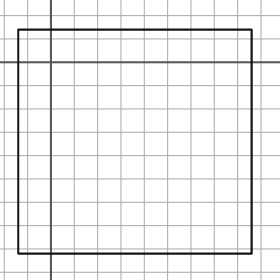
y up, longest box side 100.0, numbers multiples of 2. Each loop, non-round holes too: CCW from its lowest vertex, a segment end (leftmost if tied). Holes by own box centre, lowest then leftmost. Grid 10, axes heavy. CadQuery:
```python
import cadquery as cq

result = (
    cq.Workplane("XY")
    .moveTo(-14.0, -82.0)
    .lineTo(86.0, -82.0)
    .lineTo(86.0, 14.0)
    .lineTo(-14.0, 14.0)
    .close()
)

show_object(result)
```